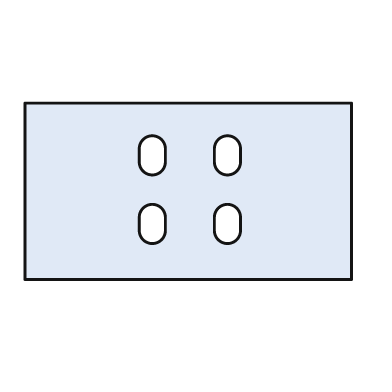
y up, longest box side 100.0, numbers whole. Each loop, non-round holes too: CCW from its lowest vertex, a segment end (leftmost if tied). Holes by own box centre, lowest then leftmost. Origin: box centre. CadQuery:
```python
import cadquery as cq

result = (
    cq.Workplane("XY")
    .moveTo(-50.0, -27.0)
    .lineTo(50.0, -27.0)
    .lineTo(50.0, 27.0)
    .lineTo(-50.0, 27.0)
    .close()
    .moveTo(-15.0, -12.0)
    .threePointArc((-11.0, -16.0), (-7.0, -12.0))
    .lineTo(-7.0, -8.0)
    .threePointArc((-11.0, -4.0), (-15.0, -8.0))
    .close()
    .moveTo(8.0, -12.0)
    .threePointArc((12.0, -16.0), (16.0, -12.0))
    .lineTo(16.0, -8.0)
    .threePointArc((12.0, -4.0), (8.0, -8.0))
    .close()
    .moveTo(-15.0, 9.0)
    .threePointArc((-11.0, 5.0), (-7.0, 9.0))
    .lineTo(-7.0, 13.0)
    .threePointArc((-11.0, 17.0), (-15.0, 13.0))
    .close()
    .moveTo(8.0, 9.0)
    .threePointArc((12.0, 5.0), (16.0, 9.0))
    .lineTo(16.0, 13.0)
    .threePointArc((12.0, 17.0), (8.0, 13.0))
    .close()
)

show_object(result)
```